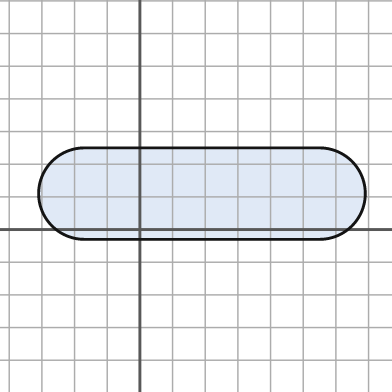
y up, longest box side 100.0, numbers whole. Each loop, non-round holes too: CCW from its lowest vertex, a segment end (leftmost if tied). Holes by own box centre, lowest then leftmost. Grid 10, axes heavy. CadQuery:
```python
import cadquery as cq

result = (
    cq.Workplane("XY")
    .moveTo(-17.0, -3.0)
    .lineTo(55.0, -3.0)
    .threePointArc((69.0, 11.0), (55.0, 25.0))
    .lineTo(-17.0, 25.0)
    .threePointArc((-31.0, 11.0), (-17.0, -3.0))
    .close()
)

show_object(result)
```